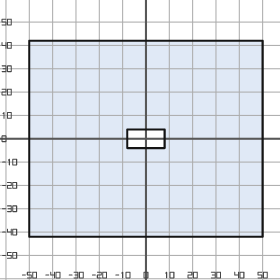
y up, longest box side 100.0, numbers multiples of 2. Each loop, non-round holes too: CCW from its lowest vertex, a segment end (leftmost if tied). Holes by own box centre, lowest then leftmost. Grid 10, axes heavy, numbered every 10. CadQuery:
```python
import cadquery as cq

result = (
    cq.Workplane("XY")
    .moveTo(-50.0, -42.0)
    .lineTo(50.0, -42.0)
    .lineTo(50.0, 42.0)
    .lineTo(-50.0, 42.0)
    .close()
    .moveTo(-8.0, -4.0)
    .lineTo(8.0, -4.0)
    .lineTo(8.0, 4.0)
    .lineTo(-8.0, 4.0)
    .close()
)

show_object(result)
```